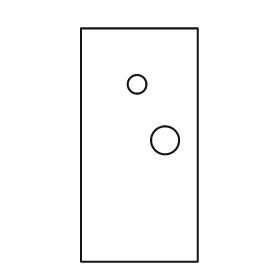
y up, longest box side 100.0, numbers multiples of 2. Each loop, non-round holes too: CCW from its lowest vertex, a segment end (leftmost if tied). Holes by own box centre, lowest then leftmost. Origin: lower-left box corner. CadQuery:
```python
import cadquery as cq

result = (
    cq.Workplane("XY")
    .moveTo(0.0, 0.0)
    .lineTo(50.0, 0.0)
    .lineTo(50.0, 100.0)
    .lineTo(0.0, 100.0)
    .close()
    .moveTo(36.0, 52.0)
    .circle(6.0)
    .moveTo(24.0, 76.0)
    .circle(4.0)
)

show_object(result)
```